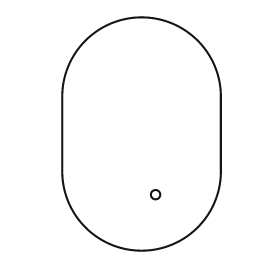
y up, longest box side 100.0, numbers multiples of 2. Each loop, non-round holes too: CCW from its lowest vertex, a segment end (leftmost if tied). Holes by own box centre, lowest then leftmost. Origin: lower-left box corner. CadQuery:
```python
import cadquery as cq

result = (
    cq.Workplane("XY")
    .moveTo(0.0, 34.0)
    .threePointArc((34.0, 0.0), (68.0, 34.0))
    .lineTo(68.0, 66.0)
    .threePointArc((34.0, 100.0), (0.0, 66.0))
    .close()
    .moveTo(40.0, 24.0)
    .circle(2.0)
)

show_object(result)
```